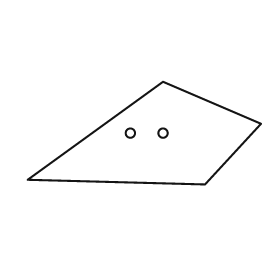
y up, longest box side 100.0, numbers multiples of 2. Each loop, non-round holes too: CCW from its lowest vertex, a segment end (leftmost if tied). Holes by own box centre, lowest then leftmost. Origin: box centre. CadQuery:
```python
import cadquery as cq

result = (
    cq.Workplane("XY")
    .moveTo(26.0, -22.0)
    .lineTo(50.0, 4.0)
    .lineTo(8.0, 22.0)
    .lineTo(-50.0, -20.0)
    .close()
    .moveTo(-6.0, 0.0)
    .circle(2.0)
    .moveTo(8.0, 0.0)
    .circle(2.0)
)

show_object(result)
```